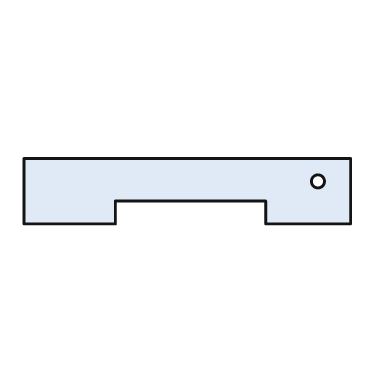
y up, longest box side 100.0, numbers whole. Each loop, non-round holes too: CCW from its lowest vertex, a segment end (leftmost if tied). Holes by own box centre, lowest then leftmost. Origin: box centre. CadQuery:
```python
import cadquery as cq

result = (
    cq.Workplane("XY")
    .moveTo(-50.0, -10.0)
    .lineTo(-22.0, -10.0)
    .lineTo(-22.0, -3.0)
    .lineTo(24.0, -3.0)
    .lineTo(24.0, -10.0)
    .lineTo(50.0, -10.0)
    .lineTo(50.0, 10.0)
    .lineTo(-50.0, 10.0)
    .close()
    .moveTo(40.0, 3.0)
    .circle(2.0)
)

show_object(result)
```